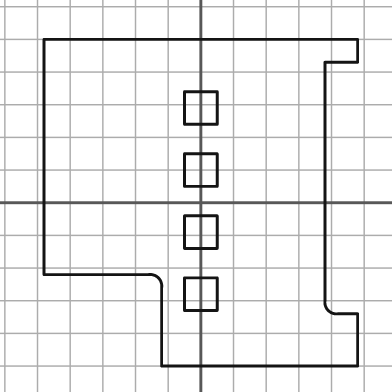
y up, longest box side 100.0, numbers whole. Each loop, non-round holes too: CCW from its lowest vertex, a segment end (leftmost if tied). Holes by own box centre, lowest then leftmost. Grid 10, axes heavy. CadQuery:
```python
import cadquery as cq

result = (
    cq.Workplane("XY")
    .moveTo(-12.0, -50.0)
    .lineTo(48.0, -50.0)
    .lineTo(48.0, -34.0)
    .lineTo(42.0, -34.0)
    .threePointArc((39.0, -33.0), (38.0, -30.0))
    .lineTo(38.0, 43.0)
    .lineTo(48.0, 43.0)
    .lineTo(48.0, 50.0)
    .lineTo(-48.0, 50.0)
    .lineTo(-48.0, -22.0)
    .lineTo(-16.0, -22.0)
    .threePointArc((-13.0, -23.0), (-12.0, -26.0))
    .close()
    .moveTo(-5.0, -33.0)
    .lineTo(5.0, -33.0)
    .lineTo(5.0, -23.0)
    .lineTo(-5.0, -23.0)
    .close()
    .moveTo(-5.0, -14.0)
    .lineTo(5.0, -14.0)
    .lineTo(5.0, -4.0)
    .lineTo(-5.0, -4.0)
    .close()
    .moveTo(-5.0, 5.0)
    .lineTo(5.0, 5.0)
    .lineTo(5.0, 15.0)
    .lineTo(-5.0, 15.0)
    .close()
    .moveTo(-5.0, 24.0)
    .lineTo(5.0, 24.0)
    .lineTo(5.0, 34.0)
    .lineTo(-5.0, 34.0)
    .close()
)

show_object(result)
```